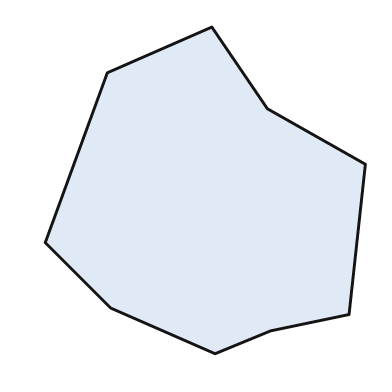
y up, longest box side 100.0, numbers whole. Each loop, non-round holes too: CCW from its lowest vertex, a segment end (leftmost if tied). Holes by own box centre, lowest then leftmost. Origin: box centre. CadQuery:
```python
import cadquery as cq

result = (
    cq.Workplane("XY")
    .moveTo(3.0, -50.0)
    .lineTo(20.0, -43.0)
    .lineTo(44.0, -38.0)
    .lineTo(49.0, 8.0)
    .lineTo(19.0, 25.0)
    .lineTo(2.0, 50.0)
    .lineTo(-30.0, 36.0)
    .lineTo(-49.0, -16.0)
    .lineTo(-29.0, -36.0)
    .close()
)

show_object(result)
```